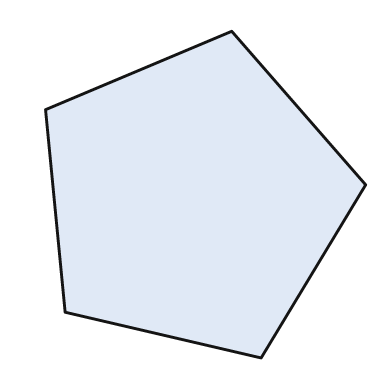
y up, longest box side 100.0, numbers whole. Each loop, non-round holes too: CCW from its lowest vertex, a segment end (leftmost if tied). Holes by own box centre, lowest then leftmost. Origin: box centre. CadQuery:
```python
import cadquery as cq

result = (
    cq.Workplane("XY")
    .moveTo(17.0, -50.0)
    .lineTo(49.0, 3.0)
    .lineTo(8.0, 50.0)
    .lineTo(-49.0, 26.0)
    .lineTo(-43.0, -36.0)
    .close()
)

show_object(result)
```